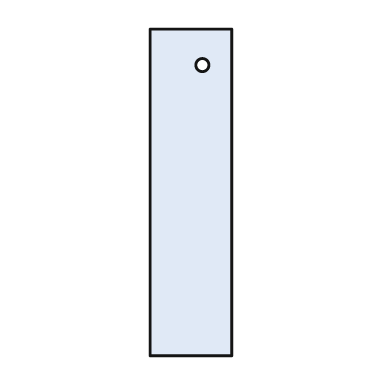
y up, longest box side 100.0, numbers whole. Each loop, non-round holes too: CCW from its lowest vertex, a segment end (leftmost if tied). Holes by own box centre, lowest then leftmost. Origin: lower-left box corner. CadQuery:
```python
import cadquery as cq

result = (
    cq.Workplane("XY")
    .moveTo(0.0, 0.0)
    .lineTo(25.0, 0.0)
    .lineTo(25.0, 100.0)
    .lineTo(0.0, 100.0)
    .close()
    .moveTo(16.0, 89.0)
    .circle(2.0)
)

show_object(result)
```